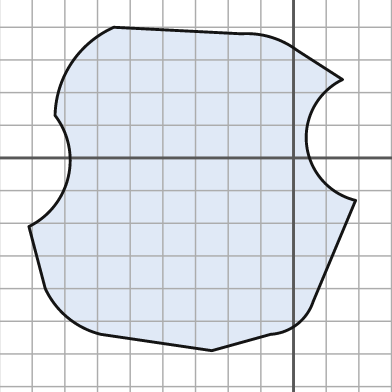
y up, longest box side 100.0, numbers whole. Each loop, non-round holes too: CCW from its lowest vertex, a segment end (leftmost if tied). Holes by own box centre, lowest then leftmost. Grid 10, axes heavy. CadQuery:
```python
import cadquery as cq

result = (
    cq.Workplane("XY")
    .moveTo(-25.0, -59.0)
    .lineTo(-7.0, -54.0)
    .threePointArc((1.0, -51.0), (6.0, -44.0))
    .lineTo(19.0, -13.0)
    .threePointArc((4.0, 4.0), (15.0, 24.0))
    .lineTo(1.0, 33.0)
    .threePointArc((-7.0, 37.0), (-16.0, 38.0))
    .lineTo(-55.0, 40.0)
    .threePointArc((-68.0, 29.0), (-73.0, 13.0))
    .threePointArc((-69.0, -6.0), (-81.0, -21.0))
    .lineTo(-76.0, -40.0)
    .threePointArc((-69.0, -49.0), (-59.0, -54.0))
    .close()
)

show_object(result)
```